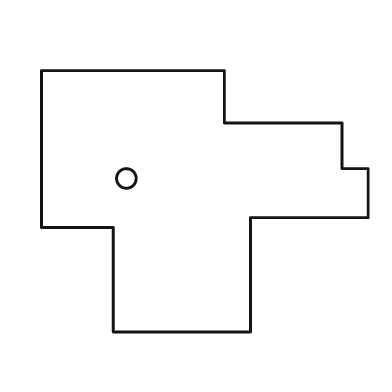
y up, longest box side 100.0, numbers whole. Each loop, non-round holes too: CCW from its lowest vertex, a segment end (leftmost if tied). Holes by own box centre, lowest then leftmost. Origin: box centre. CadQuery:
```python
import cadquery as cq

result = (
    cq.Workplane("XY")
    .moveTo(-28.0, -40.0)
    .lineTo(14.0, -40.0)
    .lineTo(14.0, -5.0)
    .lineTo(50.0, -5.0)
    .lineTo(50.0, 10.0)
    .lineTo(42.0, 10.0)
    .lineTo(42.0, 24.0)
    .lineTo(6.0, 24.0)
    .lineTo(6.0, 40.0)
    .lineTo(-50.0, 40.0)
    .lineTo(-50.0, -8.0)
    .lineTo(-28.0, -8.0)
    .close()
    .moveTo(-24.0, 7.0)
    .circle(3.0)
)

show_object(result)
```